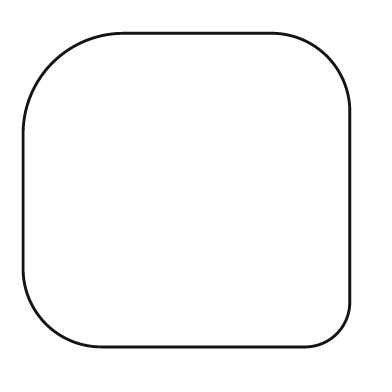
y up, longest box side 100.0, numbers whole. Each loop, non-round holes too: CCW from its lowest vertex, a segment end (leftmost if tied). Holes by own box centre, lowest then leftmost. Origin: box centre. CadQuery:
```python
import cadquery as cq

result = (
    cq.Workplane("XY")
    .moveTo(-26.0, -48.0)
    .lineTo(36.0, -48.0)
    .threePointArc((46.0, -44.0), (50.0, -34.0))
    .lineTo(50.0, 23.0)
    .threePointArc((43.0, 41.0), (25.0, 48.0))
    .lineTo(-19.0, 48.0)
    .threePointArc((-41.0, 39.0), (-50.0, 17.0))
    .lineTo(-50.0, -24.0)
    .threePointArc((-43.0, -41.0), (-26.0, -48.0))
    .close()
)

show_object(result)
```